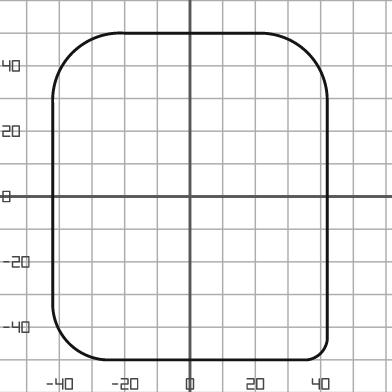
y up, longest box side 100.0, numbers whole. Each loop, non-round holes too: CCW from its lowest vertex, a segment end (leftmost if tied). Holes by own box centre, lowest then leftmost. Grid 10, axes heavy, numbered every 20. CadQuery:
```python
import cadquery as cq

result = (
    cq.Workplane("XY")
    .moveTo(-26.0, -50.0)
    .lineTo(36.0, -50.0)
    .threePointArc((40.0, -48.0), (42.0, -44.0))
    .lineTo(42.0, 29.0)
    .threePointArc((36.0, 44.0), (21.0, 50.0))
    .lineTo(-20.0, 50.0)
    .threePointArc((-36.0, 44.0), (-42.0, 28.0))
    .lineTo(-42.0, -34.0)
    .threePointArc((-37.0, -45.0), (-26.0, -50.0))
    .close()
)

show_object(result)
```